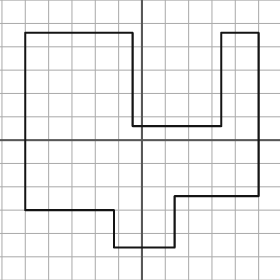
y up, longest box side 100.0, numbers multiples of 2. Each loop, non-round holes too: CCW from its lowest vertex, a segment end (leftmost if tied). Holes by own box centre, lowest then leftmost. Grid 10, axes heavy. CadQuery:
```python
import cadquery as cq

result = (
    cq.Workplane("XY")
    .moveTo(-12.0, -46.0)
    .lineTo(14.0, -46.0)
    .lineTo(14.0, -24.0)
    .lineTo(50.0, -24.0)
    .lineTo(50.0, 46.0)
    .lineTo(34.0, 46.0)
    .lineTo(34.0, 6.0)
    .lineTo(-4.0, 6.0)
    .lineTo(-4.0, 46.0)
    .lineTo(-50.0, 46.0)
    .lineTo(-50.0, -30.0)
    .lineTo(-12.0, -30.0)
    .close()
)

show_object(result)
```